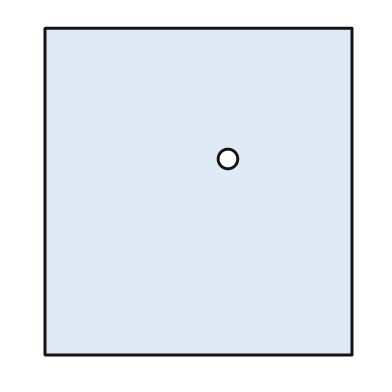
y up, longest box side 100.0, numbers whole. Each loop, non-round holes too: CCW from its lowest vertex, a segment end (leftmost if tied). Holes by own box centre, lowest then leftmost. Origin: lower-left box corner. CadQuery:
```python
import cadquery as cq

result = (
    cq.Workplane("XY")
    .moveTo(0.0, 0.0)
    .lineTo(94.0, 0.0)
    .lineTo(94.0, 100.0)
    .lineTo(0.0, 100.0)
    .close()
    .moveTo(56.0, 60.0)
    .circle(3.0)
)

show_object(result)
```